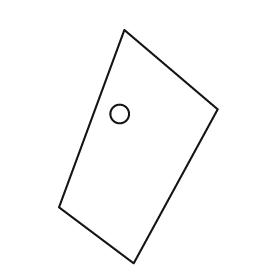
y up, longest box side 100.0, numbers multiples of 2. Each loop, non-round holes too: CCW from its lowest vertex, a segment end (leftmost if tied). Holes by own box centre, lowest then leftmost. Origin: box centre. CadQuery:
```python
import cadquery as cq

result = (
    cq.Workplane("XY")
    .moveTo(-2.0, -50.0)
    .lineTo(34.0, 16.0)
    .lineTo(-6.0, 50.0)
    .lineTo(-34.0, -26.0)
    .close()
    .moveTo(-8.0, 14.0)
    .circle(4.0)
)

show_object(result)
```